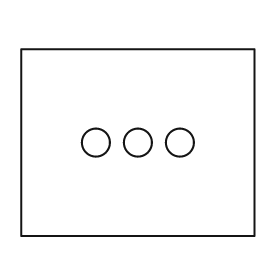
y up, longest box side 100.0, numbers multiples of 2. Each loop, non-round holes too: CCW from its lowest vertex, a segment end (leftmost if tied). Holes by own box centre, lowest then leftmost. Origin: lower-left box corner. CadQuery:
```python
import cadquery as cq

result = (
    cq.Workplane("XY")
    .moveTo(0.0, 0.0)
    .lineTo(100.0, 0.0)
    .lineTo(100.0, 80.0)
    .lineTo(0.0, 80.0)
    .close()
    .moveTo(32.0, 40.0)
    .circle(6.0)
    .moveTo(50.0, 40.0)
    .circle(6.0)
    .moveTo(68.0, 40.0)
    .circle(6.0)
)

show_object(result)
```